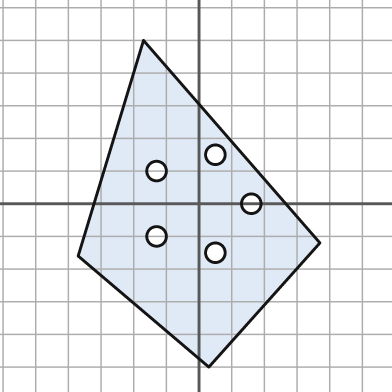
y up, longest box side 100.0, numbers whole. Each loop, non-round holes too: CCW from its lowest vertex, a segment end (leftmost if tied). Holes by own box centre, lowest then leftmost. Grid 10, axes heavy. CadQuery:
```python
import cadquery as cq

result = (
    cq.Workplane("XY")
    .moveTo(3.0, -50.0)
    .lineTo(37.0, -12.0)
    .lineTo(-17.0, 50.0)
    .lineTo(-37.0, -16.0)
    .close()
    .moveTo(5.0, -15.0)
    .circle(3.0)
    .moveTo(-13.0, -10.0)
    .circle(3.0)
    .moveTo(16.0, 0.0)
    .circle(3.0)
    .moveTo(-13.0, 10.0)
    .circle(3.0)
    .moveTo(5.0, 15.0)
    .circle(3.0)
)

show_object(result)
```